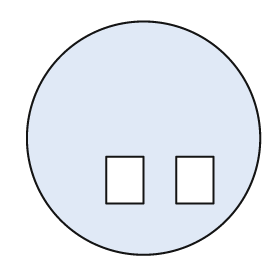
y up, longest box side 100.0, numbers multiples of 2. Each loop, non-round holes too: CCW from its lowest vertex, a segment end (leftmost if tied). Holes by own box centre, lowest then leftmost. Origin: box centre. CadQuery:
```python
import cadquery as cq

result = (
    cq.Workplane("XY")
    .moveTo(0.0, 0.0)
    .circle(50.0)
    .moveTo(-16.0, -28.0)
    .lineTo(0.0, -28.0)
    .lineTo(0.0, -8.0)
    .lineTo(-16.0, -8.0)
    .close()
    .moveTo(14.0, -28.0)
    .lineTo(30.0, -28.0)
    .lineTo(30.0, -8.0)
    .lineTo(14.0, -8.0)
    .close()
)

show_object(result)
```